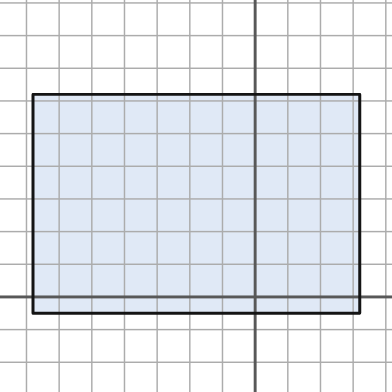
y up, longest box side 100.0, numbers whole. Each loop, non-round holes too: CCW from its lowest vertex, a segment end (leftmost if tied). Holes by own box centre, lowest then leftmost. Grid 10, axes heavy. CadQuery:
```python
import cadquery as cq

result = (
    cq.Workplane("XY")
    .moveTo(-68.0, -5.0)
    .lineTo(32.0, -5.0)
    .lineTo(32.0, 62.0)
    .lineTo(-68.0, 62.0)
    .close()
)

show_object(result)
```